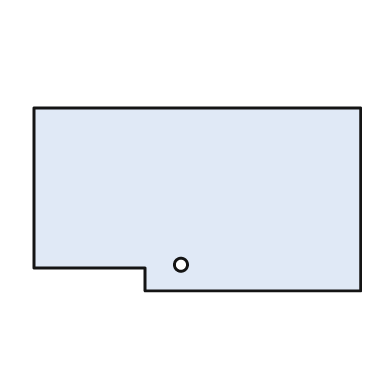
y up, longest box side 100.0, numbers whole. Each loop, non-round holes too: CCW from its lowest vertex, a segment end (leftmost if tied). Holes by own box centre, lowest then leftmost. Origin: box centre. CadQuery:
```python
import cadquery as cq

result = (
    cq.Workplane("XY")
    .moveTo(-16.0, -28.0)
    .lineTo(50.0, -28.0)
    .lineTo(50.0, 28.0)
    .lineTo(-50.0, 28.0)
    .lineTo(-50.0, -21.0)
    .lineTo(-16.0, -21.0)
    .close()
    .moveTo(-5.0, -20.0)
    .circle(2.0)
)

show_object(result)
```